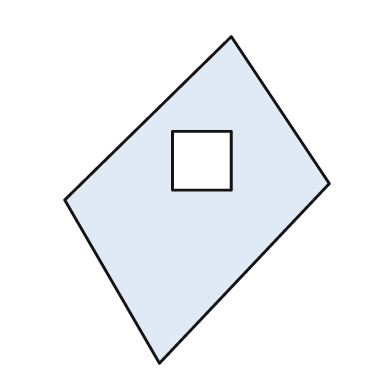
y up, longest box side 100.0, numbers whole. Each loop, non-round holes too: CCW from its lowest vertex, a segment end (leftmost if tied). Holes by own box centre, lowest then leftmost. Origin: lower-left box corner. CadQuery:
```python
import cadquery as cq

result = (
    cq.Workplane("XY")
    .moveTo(29.0, 0.0)
    .lineTo(81.0, 55.0)
    .lineTo(51.0, 100.0)
    .lineTo(0.0, 50.0)
    .close()
    .moveTo(33.0, 53.0)
    .lineTo(51.0, 53.0)
    .lineTo(51.0, 71.0)
    .lineTo(33.0, 71.0)
    .close()
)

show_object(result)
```